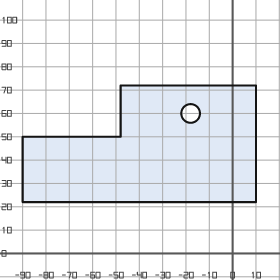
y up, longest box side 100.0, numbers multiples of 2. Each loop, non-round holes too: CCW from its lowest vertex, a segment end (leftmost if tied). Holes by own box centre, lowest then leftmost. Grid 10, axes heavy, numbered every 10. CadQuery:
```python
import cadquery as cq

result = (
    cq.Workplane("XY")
    .moveTo(-90.0, 22.0)
    .lineTo(10.0, 22.0)
    .lineTo(10.0, 72.0)
    .lineTo(-48.0, 72.0)
    .lineTo(-48.0, 50.0)
    .lineTo(-90.0, 50.0)
    .close()
    .moveTo(-18.0, 60.0)
    .circle(4.0)
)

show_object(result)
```